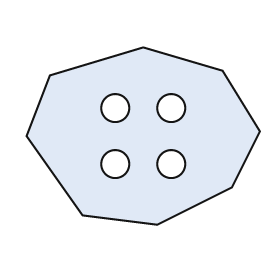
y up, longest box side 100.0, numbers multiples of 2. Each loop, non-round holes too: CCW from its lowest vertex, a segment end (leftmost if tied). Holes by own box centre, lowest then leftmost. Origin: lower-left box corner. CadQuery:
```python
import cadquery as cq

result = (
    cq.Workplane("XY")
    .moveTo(56.0, 0.0)
    .lineTo(88.0, 16.0)
    .lineTo(100.0, 40.0)
    .lineTo(84.0, 66.0)
    .lineTo(50.0, 76.0)
    .lineTo(10.0, 64.0)
    .lineTo(0.0, 38.0)
    .lineTo(24.0, 4.0)
    .close()
    .moveTo(38.0, 26.0)
    .circle(6.0)
    .moveTo(62.0, 26.0)
    .circle(6.0)
    .moveTo(38.0, 50.0)
    .circle(6.0)
    .moveTo(62.0, 50.0)
    .circle(6.0)
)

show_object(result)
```